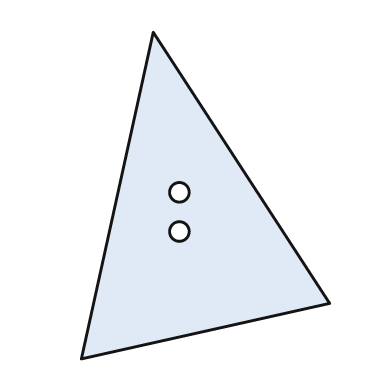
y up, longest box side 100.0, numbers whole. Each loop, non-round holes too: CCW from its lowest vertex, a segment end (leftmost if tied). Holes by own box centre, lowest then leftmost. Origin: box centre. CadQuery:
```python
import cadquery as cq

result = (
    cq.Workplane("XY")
    .moveTo(-38.0, -50.0)
    .lineTo(38.0, -33.0)
    .lineTo(-16.0, 50.0)
    .close()
    .moveTo(-8.0, -11.0)
    .circle(3.0)
    .moveTo(-8.0, 1.0)
    .circle(3.0)
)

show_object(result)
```